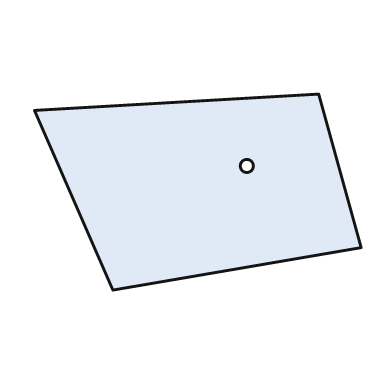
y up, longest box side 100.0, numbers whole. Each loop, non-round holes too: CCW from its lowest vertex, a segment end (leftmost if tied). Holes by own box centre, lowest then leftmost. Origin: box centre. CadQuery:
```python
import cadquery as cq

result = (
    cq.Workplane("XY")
    .moveTo(-26.0, -30.0)
    .lineTo(50.0, -17.0)
    .lineTo(37.0, 30.0)
    .lineTo(-50.0, 25.0)
    .close()
    .moveTo(15.0, 8.0)
    .circle(2.0)
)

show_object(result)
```